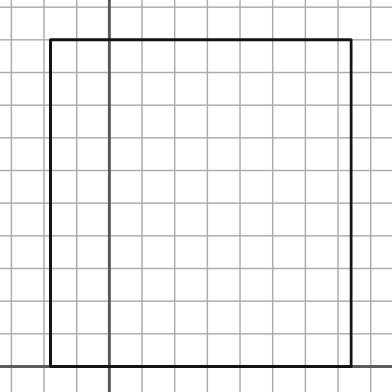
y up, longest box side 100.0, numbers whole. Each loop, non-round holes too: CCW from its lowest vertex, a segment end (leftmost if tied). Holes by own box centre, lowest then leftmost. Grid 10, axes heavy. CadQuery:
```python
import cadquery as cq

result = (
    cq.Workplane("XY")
    .moveTo(-18.0, 0.0)
    .lineTo(74.0, 0.0)
    .lineTo(74.0, 100.0)
    .lineTo(-18.0, 100.0)
    .close()
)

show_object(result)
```